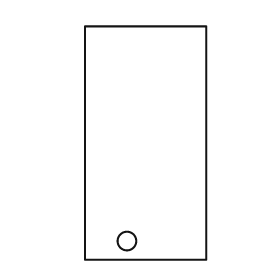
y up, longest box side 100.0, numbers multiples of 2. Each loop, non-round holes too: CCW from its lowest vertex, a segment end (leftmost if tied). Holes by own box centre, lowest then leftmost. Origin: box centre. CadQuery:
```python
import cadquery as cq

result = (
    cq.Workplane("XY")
    .moveTo(-26.0, -50.0)
    .lineTo(26.0, -50.0)
    .lineTo(26.0, 50.0)
    .lineTo(-26.0, 50.0)
    .close()
    .moveTo(-8.0, -42.0)
    .circle(4.0)
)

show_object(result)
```